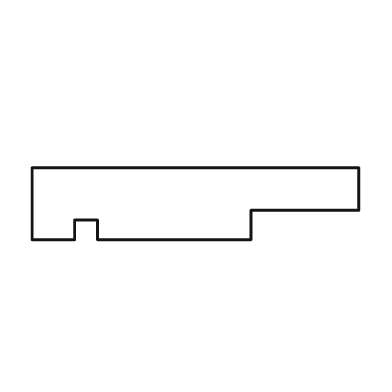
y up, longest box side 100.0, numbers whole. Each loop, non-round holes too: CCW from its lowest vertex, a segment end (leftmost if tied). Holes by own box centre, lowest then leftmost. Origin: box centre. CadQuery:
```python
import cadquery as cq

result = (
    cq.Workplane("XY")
    .moveTo(-50.0, -11.0)
    .lineTo(-37.0, -11.0)
    .lineTo(-37.0, -5.0)
    .lineTo(-30.0, -5.0)
    .lineTo(-30.0, -11.0)
    .lineTo(17.0, -11.0)
    .lineTo(17.0, -2.0)
    .lineTo(50.0, -2.0)
    .lineTo(50.0, 11.0)
    .lineTo(-50.0, 11.0)
    .close()
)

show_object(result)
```